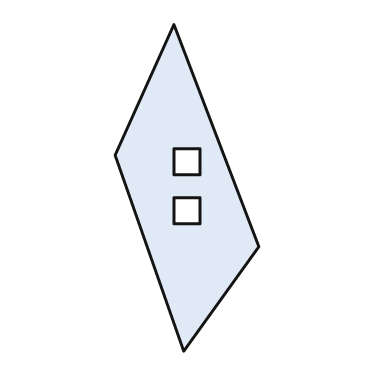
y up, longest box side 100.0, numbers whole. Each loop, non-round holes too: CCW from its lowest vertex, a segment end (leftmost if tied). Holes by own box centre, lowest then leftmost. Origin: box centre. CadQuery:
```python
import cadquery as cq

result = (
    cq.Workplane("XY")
    .moveTo(-1.0, -50.0)
    .lineTo(22.0, -18.0)
    .lineTo(-4.0, 50.0)
    .lineTo(-22.0, 10.0)
    .close()
    .moveTo(-4.0, -11.0)
    .lineTo(4.0, -11.0)
    .lineTo(4.0, -3.0)
    .lineTo(-4.0, -3.0)
    .close()
    .moveTo(-4.0, 4.0)
    .lineTo(4.0, 4.0)
    .lineTo(4.0, 12.0)
    .lineTo(-4.0, 12.0)
    .close()
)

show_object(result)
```